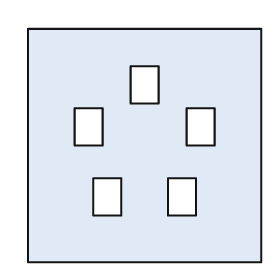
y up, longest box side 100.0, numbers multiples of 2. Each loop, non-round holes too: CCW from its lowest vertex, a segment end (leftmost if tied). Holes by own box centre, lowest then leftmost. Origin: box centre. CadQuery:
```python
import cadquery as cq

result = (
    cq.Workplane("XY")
    .moveTo(-50.0, -50.0)
    .lineTo(50.0, -50.0)
    .lineTo(50.0, 50.0)
    .lineTo(-50.0, 50.0)
    .close()
    .moveTo(-22.0, -30.0)
    .lineTo(-10.0, -30.0)
    .lineTo(-10.0, -14.0)
    .lineTo(-22.0, -14.0)
    .close()
    .moveTo(10.0, -30.0)
    .lineTo(22.0, -30.0)
    .lineTo(22.0, -14.0)
    .lineTo(10.0, -14.0)
    .close()
    .moveTo(-30.0, 0.0)
    .lineTo(-18.0, 0.0)
    .lineTo(-18.0, 16.0)
    .lineTo(-30.0, 16.0)
    .close()
    .moveTo(18.0, 0.0)
    .lineTo(30.0, 0.0)
    .lineTo(30.0, 16.0)
    .lineTo(18.0, 16.0)
    .close()
    .moveTo(-6.0, 18.0)
    .lineTo(6.0, 18.0)
    .lineTo(6.0, 34.0)
    .lineTo(-6.0, 34.0)
    .close()
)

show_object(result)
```